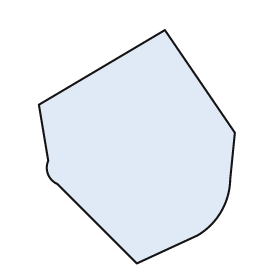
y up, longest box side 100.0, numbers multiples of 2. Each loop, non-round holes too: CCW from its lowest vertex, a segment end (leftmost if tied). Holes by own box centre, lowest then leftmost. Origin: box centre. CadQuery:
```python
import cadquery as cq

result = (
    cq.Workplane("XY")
    .moveTo(0.0, -50.0)
    .lineTo(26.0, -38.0)
    .threePointArc((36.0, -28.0), (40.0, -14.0))
    .lineTo(42.0, 6.0)
    .lineTo(12.0, 50.0)
    .lineTo(-42.0, 18.0)
    .lineTo(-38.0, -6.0)
    .threePointArc((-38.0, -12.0), (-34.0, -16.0))
    .close()
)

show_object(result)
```